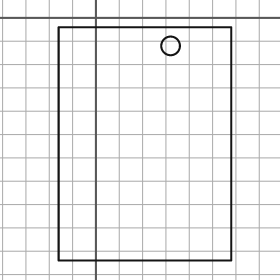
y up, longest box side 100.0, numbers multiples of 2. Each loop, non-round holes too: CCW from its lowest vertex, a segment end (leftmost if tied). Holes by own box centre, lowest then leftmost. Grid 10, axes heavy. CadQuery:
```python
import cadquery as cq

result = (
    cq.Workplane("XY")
    .moveTo(-16.0, -104.0)
    .lineTo(58.0, -104.0)
    .lineTo(58.0, -4.0)
    .lineTo(-16.0, -4.0)
    .close()
    .moveTo(32.0, -12.0)
    .circle(4.0)
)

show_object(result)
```